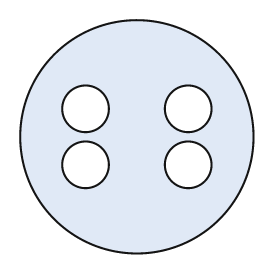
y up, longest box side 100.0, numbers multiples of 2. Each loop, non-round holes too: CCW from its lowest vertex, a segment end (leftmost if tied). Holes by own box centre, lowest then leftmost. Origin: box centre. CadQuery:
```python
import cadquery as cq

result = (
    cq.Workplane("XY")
    .moveTo(0.0, 0.0)
    .circle(50.0)
    .moveTo(-22.0, -12.0)
    .circle(10.0)
    .moveTo(22.0, -12.0)
    .circle(10.0)
    .moveTo(-22.0, 12.0)
    .circle(10.0)
    .moveTo(22.0, 12.0)
    .circle(10.0)
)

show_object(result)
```